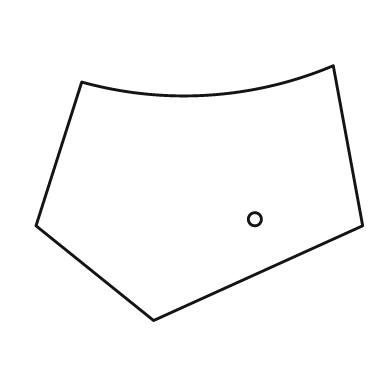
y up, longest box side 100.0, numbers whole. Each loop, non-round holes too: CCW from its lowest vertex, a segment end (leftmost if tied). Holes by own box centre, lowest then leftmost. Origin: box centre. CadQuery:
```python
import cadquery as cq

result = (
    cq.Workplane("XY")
    .moveTo(-14.0, -39.0)
    .lineTo(50.0, -10.0)
    .lineTo(41.0, 39.0)
    .threePointArc((3.0, 30.0), (-36.0, 34.0))
    .lineTo(-50.0, -10.0)
    .close()
    .moveTo(17.0, -8.0)
    .circle(2.0)
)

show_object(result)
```